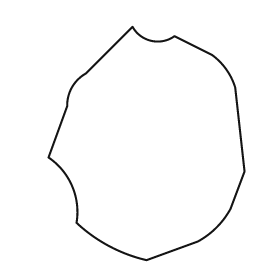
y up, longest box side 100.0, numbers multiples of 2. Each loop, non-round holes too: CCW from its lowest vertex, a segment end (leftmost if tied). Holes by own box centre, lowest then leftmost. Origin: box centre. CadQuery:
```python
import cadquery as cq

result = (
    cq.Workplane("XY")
    .moveTo(0.0, -50.0)
    .lineTo(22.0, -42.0)
    .threePointArc((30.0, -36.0), (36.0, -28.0))
    .lineTo(42.0, -12.0)
    .lineTo(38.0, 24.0)
    .threePointArc((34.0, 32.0), (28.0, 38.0))
    .lineTo(12.0, 46.0)
    .threePointArc((2.0, 44.0), (-6.0, 50.0))
    .lineTo(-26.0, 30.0)
    .threePointArc((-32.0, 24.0), (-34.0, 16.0))
    .lineTo(-42.0, -6.0)
    .threePointArc((-32.0, -18.0), (-30.0, -34.0))
    .threePointArc((-16.0, -44.0), (0.0, -50.0))
    .close()
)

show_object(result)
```